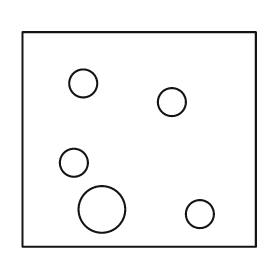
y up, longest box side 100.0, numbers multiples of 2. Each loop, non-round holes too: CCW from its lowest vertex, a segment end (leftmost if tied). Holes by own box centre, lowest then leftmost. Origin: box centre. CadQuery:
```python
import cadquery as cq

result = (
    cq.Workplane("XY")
    .moveTo(-50.0, -46.0)
    .lineTo(50.0, -46.0)
    .lineTo(50.0, 46.0)
    .lineTo(-50.0, 46.0)
    .close()
    .moveTo(26.0, -32.0)
    .circle(6.0)
    .moveTo(-16.0, -30.0)
    .circle(10.0)
    .moveTo(-28.0, -10.0)
    .circle(6.0)
    .moveTo(14.0, 16.0)
    .circle(6.0)
    .moveTo(-24.0, 24.0)
    .circle(6.0)
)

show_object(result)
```